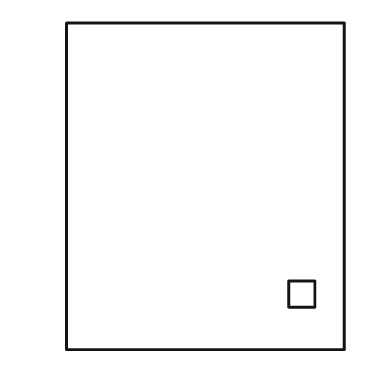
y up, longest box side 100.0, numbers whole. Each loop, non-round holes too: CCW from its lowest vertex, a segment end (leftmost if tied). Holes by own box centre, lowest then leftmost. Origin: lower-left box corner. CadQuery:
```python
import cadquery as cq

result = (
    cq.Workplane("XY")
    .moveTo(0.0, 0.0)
    .lineTo(85.0, 0.0)
    .lineTo(85.0, 100.0)
    .lineTo(0.0, 100.0)
    .close()
    .moveTo(68.0, 13.0)
    .lineTo(76.0, 13.0)
    .lineTo(76.0, 21.0)
    .lineTo(68.0, 21.0)
    .close()
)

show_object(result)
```